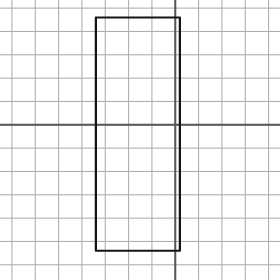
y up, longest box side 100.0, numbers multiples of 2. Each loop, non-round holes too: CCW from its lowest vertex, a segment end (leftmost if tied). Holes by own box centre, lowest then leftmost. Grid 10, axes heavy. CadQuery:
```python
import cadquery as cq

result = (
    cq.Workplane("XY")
    .moveTo(-34.0, -54.0)
    .lineTo(2.0, -54.0)
    .lineTo(2.0, 46.0)
    .lineTo(-34.0, 46.0)
    .close()
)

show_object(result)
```